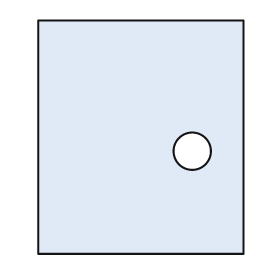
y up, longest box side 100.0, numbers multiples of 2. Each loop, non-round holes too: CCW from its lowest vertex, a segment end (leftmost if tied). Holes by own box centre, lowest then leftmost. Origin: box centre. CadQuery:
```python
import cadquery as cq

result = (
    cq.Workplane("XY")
    .moveTo(-44.0, -50.0)
    .lineTo(44.0, -50.0)
    .lineTo(44.0, 50.0)
    .lineTo(-44.0, 50.0)
    .close()
    .moveTo(22.0, -6.0)
    .circle(8.0)
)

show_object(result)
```